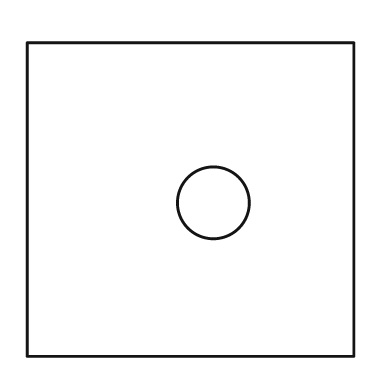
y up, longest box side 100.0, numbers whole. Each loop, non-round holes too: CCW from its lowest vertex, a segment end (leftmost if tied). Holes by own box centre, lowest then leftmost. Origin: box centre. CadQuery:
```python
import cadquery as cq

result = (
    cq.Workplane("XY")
    .moveTo(-50.0, -48.0)
    .lineTo(50.0, -48.0)
    .lineTo(50.0, 48.0)
    .lineTo(-50.0, 48.0)
    .close()
    .moveTo(7.0, -1.0)
    .circle(11.0)
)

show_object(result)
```